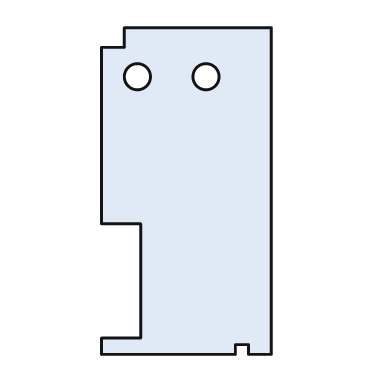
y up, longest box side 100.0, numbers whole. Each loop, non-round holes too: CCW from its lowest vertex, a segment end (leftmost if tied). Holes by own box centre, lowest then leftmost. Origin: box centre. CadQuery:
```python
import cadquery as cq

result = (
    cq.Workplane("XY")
    .moveTo(-26.0, -50.0)
    .lineTo(15.0, -50.0)
    .lineTo(15.0, -47.0)
    .lineTo(19.0, -47.0)
    .lineTo(19.0, -50.0)
    .lineTo(26.0, -50.0)
    .lineTo(26.0, 50.0)
    .lineTo(-19.0, 50.0)
    .lineTo(-19.0, 44.0)
    .lineTo(-26.0, 44.0)
    .lineTo(-26.0, -10.0)
    .lineTo(-14.0, -10.0)
    .lineTo(-14.0, -45.0)
    .lineTo(-26.0, -45.0)
    .close()
    .moveTo(-15.0, 35.0)
    .circle(4.0)
    .moveTo(6.0, 35.0)
    .circle(4.0)
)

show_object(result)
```